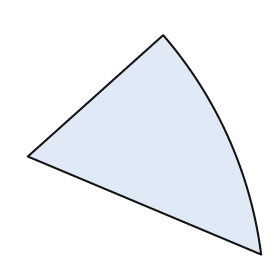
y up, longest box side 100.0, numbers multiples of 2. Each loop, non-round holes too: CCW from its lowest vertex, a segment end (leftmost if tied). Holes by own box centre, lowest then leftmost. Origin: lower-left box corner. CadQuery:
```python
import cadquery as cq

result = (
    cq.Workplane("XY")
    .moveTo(100.0, 0.0)
    .threePointArc((86.0, 50.0), (58.0, 94.0))
    .lineTo(0.0, 42.0)
    .close()
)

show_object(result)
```